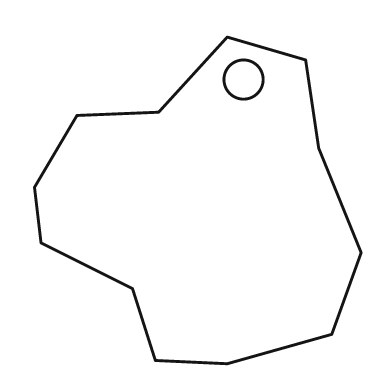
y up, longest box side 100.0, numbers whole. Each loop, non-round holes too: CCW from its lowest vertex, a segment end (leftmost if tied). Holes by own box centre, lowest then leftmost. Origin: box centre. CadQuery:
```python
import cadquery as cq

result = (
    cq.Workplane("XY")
    .moveTo(9.0, -50.0)
    .lineTo(41.0, -41.0)
    .lineTo(50.0, -16.0)
    .lineTo(37.0, 16.0)
    .lineTo(33.0, 43.0)
    .lineTo(9.0, 50.0)
    .lineTo(-12.0, 27.0)
    .lineTo(-37.0, 26.0)
    .lineTo(-50.0, 4.0)
    .lineTo(-48.0, -13.0)
    .lineTo(-20.0, -27.0)
    .lineTo(-13.0, -49.0)
    .close()
    .moveTo(14.0, 37.0)
    .circle(6.0)
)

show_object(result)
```